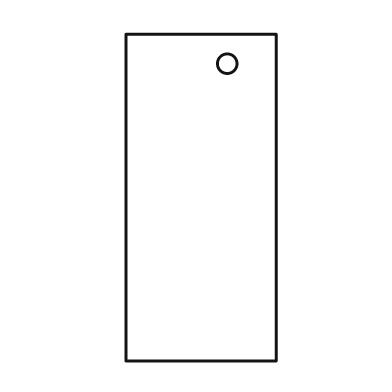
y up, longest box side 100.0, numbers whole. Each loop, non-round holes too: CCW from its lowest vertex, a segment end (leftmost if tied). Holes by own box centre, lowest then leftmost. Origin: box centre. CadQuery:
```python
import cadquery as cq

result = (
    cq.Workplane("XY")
    .moveTo(-23.0, -50.0)
    .lineTo(23.0, -50.0)
    .lineTo(23.0, 50.0)
    .lineTo(-23.0, 50.0)
    .close()
    .moveTo(8.0, 41.0)
    .circle(3.0)
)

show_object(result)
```